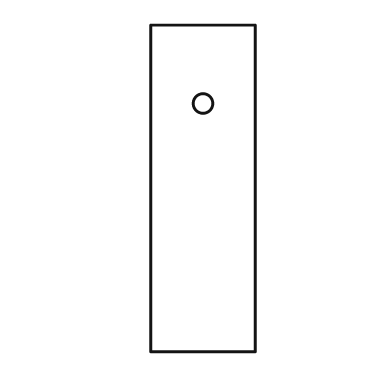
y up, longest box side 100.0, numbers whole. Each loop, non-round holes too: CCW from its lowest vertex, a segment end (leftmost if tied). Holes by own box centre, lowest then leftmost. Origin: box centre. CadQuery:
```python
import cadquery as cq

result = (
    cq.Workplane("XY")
    .moveTo(-16.0, -50.0)
    .lineTo(16.0, -50.0)
    .lineTo(16.0, 50.0)
    .lineTo(-16.0, 50.0)
    .close()
    .moveTo(0.0, 26.0)
    .circle(3.0)
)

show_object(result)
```